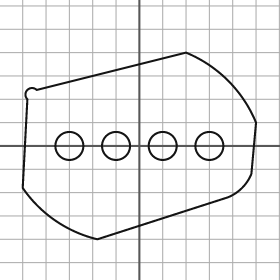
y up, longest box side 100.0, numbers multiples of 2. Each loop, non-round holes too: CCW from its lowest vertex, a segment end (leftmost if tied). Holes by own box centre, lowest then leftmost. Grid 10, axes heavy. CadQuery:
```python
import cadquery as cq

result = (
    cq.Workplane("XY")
    .moveTo(-18.0, -40.0)
    .lineTo(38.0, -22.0)
    .threePointArc((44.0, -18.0), (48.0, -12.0))
    .lineTo(50.0, 10.0)
    .threePointArc((38.0, 28.0), (20.0, 40.0))
    .lineTo(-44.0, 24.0)
    .threePointArc((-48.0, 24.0), (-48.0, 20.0))
    .lineTo(-50.0, -18.0)
    .threePointArc((-36.0, -32.0), (-18.0, -40.0))
    .close()
    .moveTo(-30.0, 0.0)
    .circle(6.0)
    .moveTo(-10.0, 0.0)
    .circle(6.0)
    .moveTo(10.0, 0.0)
    .circle(6.0)
    .moveTo(30.0, 0.0)
    .circle(6.0)
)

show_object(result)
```